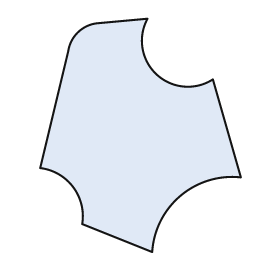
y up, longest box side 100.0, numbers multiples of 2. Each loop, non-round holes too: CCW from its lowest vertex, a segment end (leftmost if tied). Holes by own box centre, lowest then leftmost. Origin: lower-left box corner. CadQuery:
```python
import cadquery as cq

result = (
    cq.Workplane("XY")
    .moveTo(48.0, 0.0)
    .threePointArc((60.0, 24.0), (86.0, 32.0))
    .lineTo(74.0, 74.0)
    .threePointArc((50.0, 76.0), (46.0, 100.0))
    .lineTo(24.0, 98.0)
    .threePointArc((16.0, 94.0), (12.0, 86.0))
    .lineTo(0.0, 36.0)
    .threePointArc((14.0, 28.0), (18.0, 12.0))
    .close()
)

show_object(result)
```